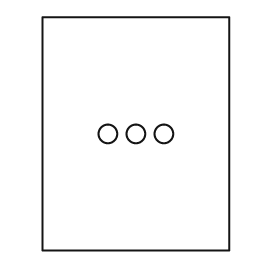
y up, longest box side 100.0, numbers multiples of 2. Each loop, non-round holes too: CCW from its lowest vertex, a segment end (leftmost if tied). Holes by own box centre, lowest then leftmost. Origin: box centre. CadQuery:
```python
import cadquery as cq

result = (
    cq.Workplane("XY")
    .moveTo(-40.0, -50.0)
    .lineTo(40.0, -50.0)
    .lineTo(40.0, 50.0)
    .lineTo(-40.0, 50.0)
    .close()
    .moveTo(-12.0, 0.0)
    .circle(4.0)
    .moveTo(0.0, 0.0)
    .circle(4.0)
    .moveTo(12.0, 0.0)
    .circle(4.0)
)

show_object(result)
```